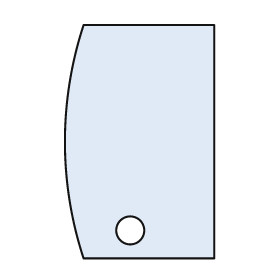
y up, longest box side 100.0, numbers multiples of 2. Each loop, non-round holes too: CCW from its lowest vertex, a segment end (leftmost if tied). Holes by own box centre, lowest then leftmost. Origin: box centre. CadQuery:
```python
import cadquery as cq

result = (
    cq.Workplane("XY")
    .moveTo(-24.0, -50.0)
    .lineTo(32.0, -50.0)
    .lineTo(32.0, 50.0)
    .lineTo(-24.0, 50.0)
    .threePointArc((-32.0, 0.0), (-24.0, -50.0))
    .close()
    .moveTo(-4.0, -38.0)
    .circle(6.0)
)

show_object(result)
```